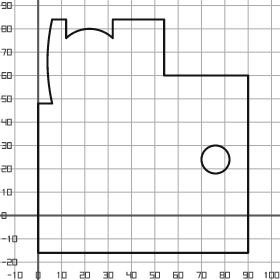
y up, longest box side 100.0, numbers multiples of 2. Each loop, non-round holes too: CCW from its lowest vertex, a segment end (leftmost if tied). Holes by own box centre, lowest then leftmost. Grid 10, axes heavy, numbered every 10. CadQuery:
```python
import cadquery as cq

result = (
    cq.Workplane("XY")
    .moveTo(0.0, -16.0)
    .lineTo(90.0, -16.0)
    .lineTo(90.0, 60.0)
    .lineTo(54.0, 60.0)
    .lineTo(54.0, 84.0)
    .lineTo(32.0, 84.0)
    .lineTo(32.0, 76.0)
    .threePointArc((22.0, 80.0), (12.0, 76.0))
    .lineTo(12.0, 84.0)
    .lineTo(6.0, 84.0)
    .threePointArc((4.0, 66.0), (6.0, 48.0))
    .lineTo(0.0, 48.0)
    .close()
    .moveTo(76.0, 24.0)
    .circle(6.0)
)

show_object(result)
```